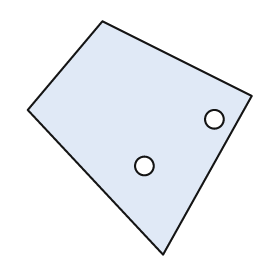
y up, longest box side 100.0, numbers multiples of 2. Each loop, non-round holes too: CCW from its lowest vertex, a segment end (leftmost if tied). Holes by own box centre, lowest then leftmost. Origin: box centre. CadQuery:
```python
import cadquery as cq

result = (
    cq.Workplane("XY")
    .moveTo(10.0, -50.0)
    .lineTo(48.0, 18.0)
    .lineTo(-16.0, 50.0)
    .lineTo(-48.0, 12.0)
    .close()
    .moveTo(2.0, -12.0)
    .circle(4.0)
    .moveTo(32.0, 8.0)
    .circle(4.0)
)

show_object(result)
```